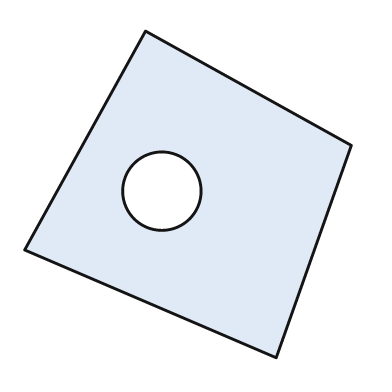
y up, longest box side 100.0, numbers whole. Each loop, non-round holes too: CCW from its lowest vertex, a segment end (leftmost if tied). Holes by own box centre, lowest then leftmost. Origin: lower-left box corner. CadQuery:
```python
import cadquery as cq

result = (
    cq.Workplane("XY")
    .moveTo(77.0, 0.0)
    .lineTo(100.0, 65.0)
    .lineTo(37.0, 100.0)
    .lineTo(0.0, 33.0)
    .close()
    .moveTo(42.0, 51.0)
    .circle(12.0)
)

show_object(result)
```